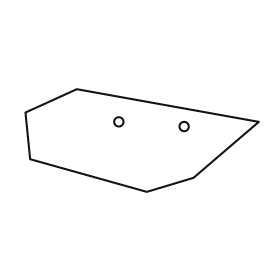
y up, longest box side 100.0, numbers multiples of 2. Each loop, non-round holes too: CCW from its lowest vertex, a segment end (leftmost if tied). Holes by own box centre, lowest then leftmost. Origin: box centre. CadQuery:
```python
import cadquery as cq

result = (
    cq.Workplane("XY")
    .moveTo(2.0, -22.0)
    .lineTo(22.0, -16.0)
    .lineTo(50.0, 8.0)
    .lineTo(-28.0, 22.0)
    .lineTo(-50.0, 12.0)
    .lineTo(-48.0, -8.0)
    .close()
    .moveTo(18.0, 6.0)
    .circle(2.0)
    .moveTo(-10.0, 8.0)
    .circle(2.0)
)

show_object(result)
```